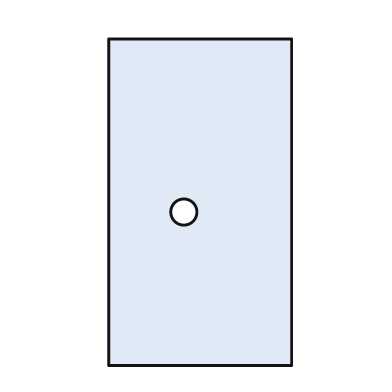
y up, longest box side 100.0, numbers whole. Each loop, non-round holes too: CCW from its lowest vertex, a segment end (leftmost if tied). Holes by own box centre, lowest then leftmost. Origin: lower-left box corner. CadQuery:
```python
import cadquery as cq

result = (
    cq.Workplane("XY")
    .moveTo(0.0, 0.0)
    .lineTo(56.0, 0.0)
    .lineTo(56.0, 100.0)
    .lineTo(0.0, 100.0)
    .close()
    .moveTo(23.0, 47.0)
    .circle(4.0)
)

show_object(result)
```